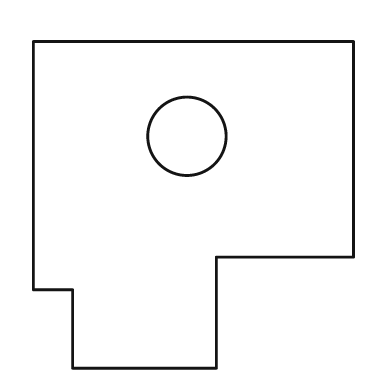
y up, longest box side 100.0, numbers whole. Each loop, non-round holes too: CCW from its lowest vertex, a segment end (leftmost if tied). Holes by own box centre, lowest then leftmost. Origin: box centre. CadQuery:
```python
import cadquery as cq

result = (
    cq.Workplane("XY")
    .moveTo(-37.0, -50.0)
    .lineTo(7.0, -50.0)
    .lineTo(7.0, -16.0)
    .lineTo(49.0, -16.0)
    .lineTo(49.0, 50.0)
    .lineTo(-49.0, 50.0)
    .lineTo(-49.0, -26.0)
    .lineTo(-37.0, -26.0)
    .close()
    .moveTo(-2.0, 21.0)
    .circle(12.0)
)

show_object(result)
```